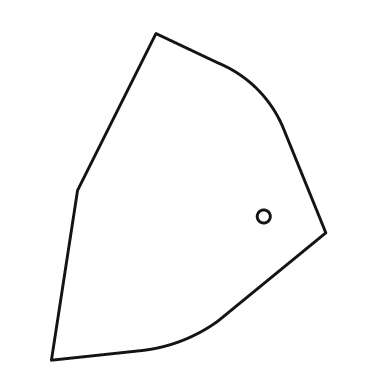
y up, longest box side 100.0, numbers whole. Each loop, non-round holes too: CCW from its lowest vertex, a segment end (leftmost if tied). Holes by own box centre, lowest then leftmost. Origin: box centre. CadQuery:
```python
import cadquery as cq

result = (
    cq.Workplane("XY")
    .moveTo(-42.0, -50.0)
    .lineTo(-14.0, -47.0)
    .threePointArc((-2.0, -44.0), (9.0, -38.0))
    .lineTo(42.0, -11.0)
    .lineTo(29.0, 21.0)
    .threePointArc((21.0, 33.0), (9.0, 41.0))
    .lineTo(-10.0, 50.0)
    .lineTo(-34.0, 2.0)
    .close()
    .moveTo(23.0, -6.0)
    .circle(2.0)
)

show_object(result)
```